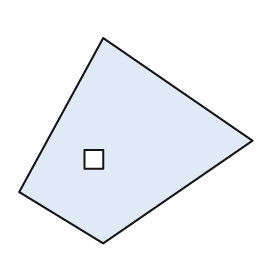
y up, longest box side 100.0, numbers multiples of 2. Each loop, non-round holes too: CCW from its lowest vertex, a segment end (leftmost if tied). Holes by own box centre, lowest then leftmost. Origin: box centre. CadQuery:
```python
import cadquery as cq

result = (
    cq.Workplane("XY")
    .moveTo(-14.0, -44.0)
    .lineTo(50.0, 0.0)
    .lineTo(-14.0, 44.0)
    .lineTo(-50.0, -22.0)
    .close()
    .moveTo(-22.0, -12.0)
    .lineTo(-14.0, -12.0)
    .lineTo(-14.0, -4.0)
    .lineTo(-22.0, -4.0)
    .close()
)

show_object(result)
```